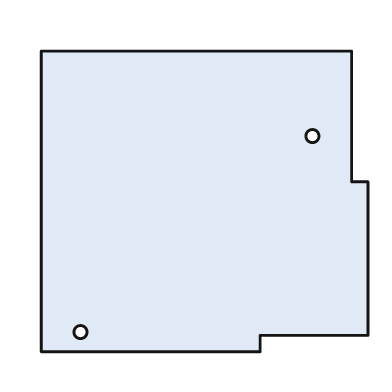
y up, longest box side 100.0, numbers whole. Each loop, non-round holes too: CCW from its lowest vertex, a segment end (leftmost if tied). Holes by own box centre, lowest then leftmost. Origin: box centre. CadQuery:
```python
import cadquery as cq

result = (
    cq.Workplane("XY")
    .moveTo(-50.0, -46.0)
    .lineTo(17.0, -46.0)
    .lineTo(17.0, -41.0)
    .lineTo(50.0, -41.0)
    .lineTo(50.0, 6.0)
    .lineTo(45.0, 6.0)
    .lineTo(45.0, 46.0)
    .lineTo(-50.0, 46.0)
    .close()
    .moveTo(-38.0, -40.0)
    .circle(2.0)
    .moveTo(33.0, 20.0)
    .circle(2.0)
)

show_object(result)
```